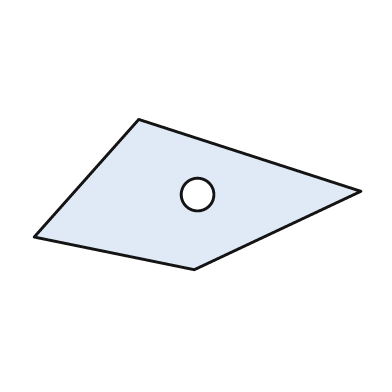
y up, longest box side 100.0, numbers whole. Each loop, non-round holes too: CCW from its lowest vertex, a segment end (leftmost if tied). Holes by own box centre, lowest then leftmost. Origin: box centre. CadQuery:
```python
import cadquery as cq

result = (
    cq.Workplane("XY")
    .moveTo(-1.0, -23.0)
    .lineTo(50.0, 1.0)
    .lineTo(-18.0, 23.0)
    .lineTo(-50.0, -13.0)
    .close()
    .moveTo(0.0, 0.0)
    .circle(5.0)
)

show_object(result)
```